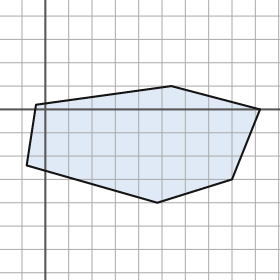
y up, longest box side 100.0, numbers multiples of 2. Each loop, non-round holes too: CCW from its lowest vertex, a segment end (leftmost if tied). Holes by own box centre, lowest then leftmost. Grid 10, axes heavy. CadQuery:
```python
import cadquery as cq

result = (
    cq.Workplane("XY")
    .moveTo(48.0, -40.0)
    .lineTo(80.0, -30.0)
    .lineTo(92.0, 0.0)
    .lineTo(54.0, 10.0)
    .lineTo(-4.0, 2.0)
    .lineTo(-8.0, -24.0)
    .close()
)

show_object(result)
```